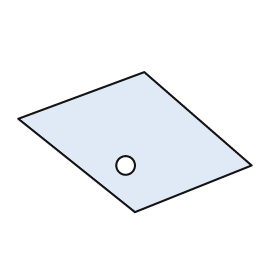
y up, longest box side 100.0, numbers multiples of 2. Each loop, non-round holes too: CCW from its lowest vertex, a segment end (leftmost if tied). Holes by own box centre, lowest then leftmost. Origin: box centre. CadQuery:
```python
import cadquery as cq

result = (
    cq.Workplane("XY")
    .moveTo(0.0, -30.0)
    .lineTo(50.0, -10.0)
    .lineTo(4.0, 30.0)
    .lineTo(-50.0, 10.0)
    .close()
    .moveTo(-4.0, -10.0)
    .circle(4.0)
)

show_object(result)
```